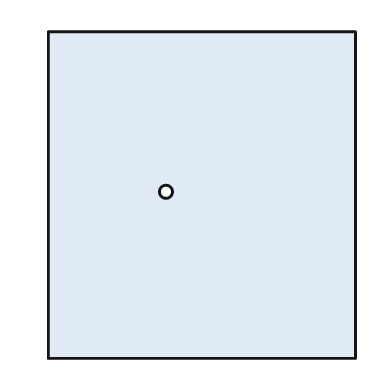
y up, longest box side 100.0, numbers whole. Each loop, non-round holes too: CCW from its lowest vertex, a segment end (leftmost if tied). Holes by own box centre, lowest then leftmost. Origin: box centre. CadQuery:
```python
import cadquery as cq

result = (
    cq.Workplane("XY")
    .moveTo(-47.0, -50.0)
    .lineTo(47.0, -50.0)
    .lineTo(47.0, 50.0)
    .lineTo(-47.0, 50.0)
    .close()
    .moveTo(-11.0, 1.0)
    .circle(2.0)
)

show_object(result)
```